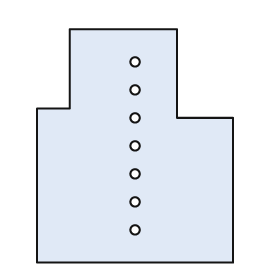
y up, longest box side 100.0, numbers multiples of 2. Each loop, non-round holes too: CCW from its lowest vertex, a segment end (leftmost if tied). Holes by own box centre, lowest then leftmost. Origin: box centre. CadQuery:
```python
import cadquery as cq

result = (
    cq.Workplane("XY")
    .moveTo(-42.0, -50.0)
    .lineTo(42.0, -50.0)
    .lineTo(42.0, 12.0)
    .lineTo(18.0, 12.0)
    .lineTo(18.0, 50.0)
    .lineTo(-28.0, 50.0)
    .lineTo(-28.0, 16.0)
    .lineTo(-42.0, 16.0)
    .close()
    .moveTo(0.0, -36.0)
    .circle(2.0)
    .moveTo(0.0, -24.0)
    .circle(2.0)
    .moveTo(0.0, -12.0)
    .circle(2.0)
    .moveTo(0.0, 0.0)
    .circle(2.0)
    .moveTo(0.0, 12.0)
    .circle(2.0)
    .moveTo(0.0, 24.0)
    .circle(2.0)
    .moveTo(0.0, 36.0)
    .circle(2.0)
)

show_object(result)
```